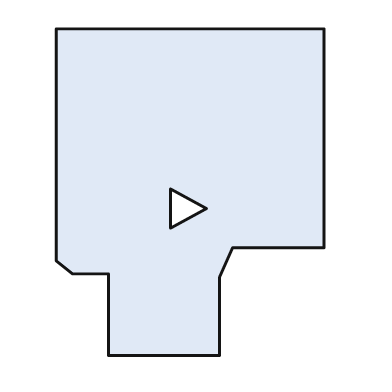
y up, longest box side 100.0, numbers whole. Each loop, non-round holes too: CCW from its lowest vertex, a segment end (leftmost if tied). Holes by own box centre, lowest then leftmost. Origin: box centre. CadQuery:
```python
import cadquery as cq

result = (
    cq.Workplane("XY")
    .moveTo(-25.0, -50.0)
    .lineTo(9.0, -50.0)
    .lineTo(9.0, -26.0)
    .lineTo(13.0, -17.0)
    .lineTo(41.0, -17.0)
    .lineTo(41.0, 50.0)
    .lineTo(-41.0, 50.0)
    .lineTo(-41.0, -21.0)
    .lineTo(-36.0, -25.0)
    .lineTo(-25.0, -25.0)
    .close()
    .moveTo(-6.0, -11.0)
    .lineTo(5.0, -5.0)
    .lineTo(-6.0, 1.0)
    .close()
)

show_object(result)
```